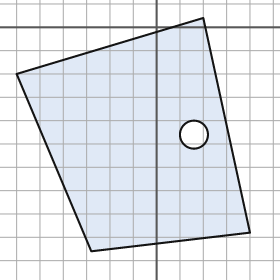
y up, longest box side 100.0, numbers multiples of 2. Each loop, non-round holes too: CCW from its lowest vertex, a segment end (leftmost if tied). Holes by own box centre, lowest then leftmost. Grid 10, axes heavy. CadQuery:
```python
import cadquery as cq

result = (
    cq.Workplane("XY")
    .moveTo(-28.0, -96.0)
    .lineTo(40.0, -88.0)
    .lineTo(20.0, 4.0)
    .lineTo(-60.0, -20.0)
    .close()
    .moveTo(16.0, -46.0)
    .circle(6.0)
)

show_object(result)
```